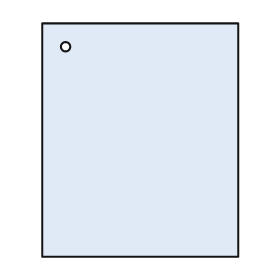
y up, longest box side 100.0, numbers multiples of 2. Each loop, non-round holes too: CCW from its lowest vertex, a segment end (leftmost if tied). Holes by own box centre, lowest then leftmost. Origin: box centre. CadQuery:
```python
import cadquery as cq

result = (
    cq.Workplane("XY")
    .moveTo(-42.0, -50.0)
    .lineTo(42.0, -50.0)
    .lineTo(42.0, 50.0)
    .lineTo(-42.0, 50.0)
    .close()
    .moveTo(-32.0, 40.0)
    .circle(2.0)
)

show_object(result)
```